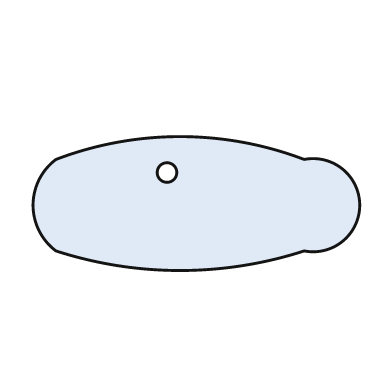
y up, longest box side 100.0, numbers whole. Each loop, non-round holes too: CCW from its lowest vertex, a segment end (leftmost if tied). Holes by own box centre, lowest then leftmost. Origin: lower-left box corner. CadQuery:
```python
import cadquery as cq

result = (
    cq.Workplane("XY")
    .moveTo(7.0, 6.0)
    .threePointArc((45.0, 0.0), (83.0, 6.0))
    .threePointArc((100.0, 20.0), (83.0, 34.0))
    .threePointArc((45.0, 41.0), (7.0, 34.0))
    .threePointArc((0.0, 20.0), (7.0, 6.0))
    .close()
    .moveTo(41.0, 30.0)
    .circle(3.0)
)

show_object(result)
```